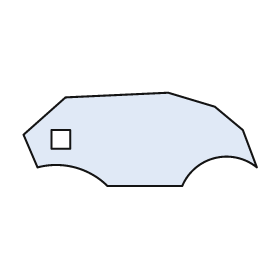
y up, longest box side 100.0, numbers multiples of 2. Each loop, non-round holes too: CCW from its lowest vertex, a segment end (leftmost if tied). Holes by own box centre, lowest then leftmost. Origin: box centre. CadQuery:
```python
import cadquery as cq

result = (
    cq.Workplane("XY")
    .moveTo(-14.0, -20.0)
    .lineTo(18.0, -20.0)
    .threePointArc((32.0, -8.0), (50.0, -12.0))
    .lineTo(44.0, 4.0)
    .lineTo(32.0, 14.0)
    .lineTo(12.0, 20.0)
    .lineTo(-32.0, 18.0)
    .lineTo(-50.0, 2.0)
    .lineTo(-44.0, -12.0)
    .threePointArc((-28.0, -12.0), (-14.0, -20.0))
    .close()
    .moveTo(-38.0, -4.0)
    .lineTo(-30.0, -4.0)
    .lineTo(-30.0, 4.0)
    .lineTo(-38.0, 4.0)
    .close()
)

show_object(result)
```